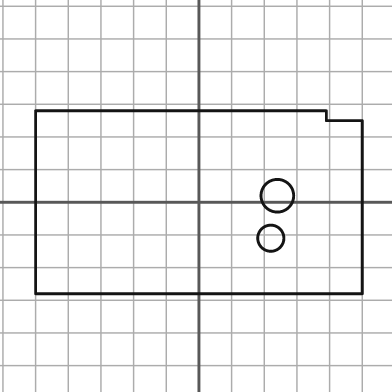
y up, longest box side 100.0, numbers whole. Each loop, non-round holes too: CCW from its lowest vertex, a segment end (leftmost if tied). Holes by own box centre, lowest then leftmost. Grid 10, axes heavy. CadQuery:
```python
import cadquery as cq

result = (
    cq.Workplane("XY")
    .moveTo(-50.0, -28.0)
    .lineTo(50.0, -28.0)
    .lineTo(50.0, 25.0)
    .lineTo(39.0, 25.0)
    .lineTo(39.0, 28.0)
    .lineTo(-50.0, 28.0)
    .close()
    .moveTo(22.0, -11.0)
    .circle(4.0)
    .moveTo(24.0, 2.0)
    .circle(5.0)
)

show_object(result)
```